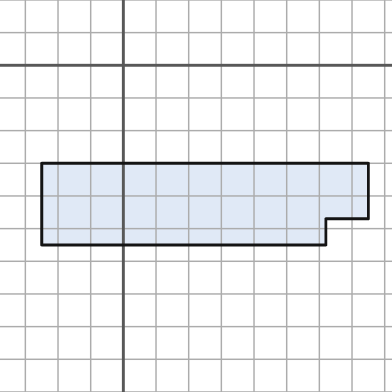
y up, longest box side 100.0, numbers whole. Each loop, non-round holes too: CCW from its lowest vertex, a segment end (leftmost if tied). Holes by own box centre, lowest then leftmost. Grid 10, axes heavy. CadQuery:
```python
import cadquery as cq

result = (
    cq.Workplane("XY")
    .moveTo(-25.0, -55.0)
    .lineTo(62.0, -55.0)
    .lineTo(62.0, -47.0)
    .lineTo(75.0, -47.0)
    .lineTo(75.0, -30.0)
    .lineTo(-25.0, -30.0)
    .close()
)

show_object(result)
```